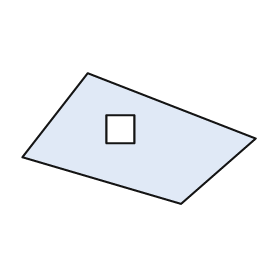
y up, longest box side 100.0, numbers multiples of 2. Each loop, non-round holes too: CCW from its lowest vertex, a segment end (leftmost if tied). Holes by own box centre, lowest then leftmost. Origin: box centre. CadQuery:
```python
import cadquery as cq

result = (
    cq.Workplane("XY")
    .moveTo(18.0, -28.0)
    .lineTo(50.0, 0.0)
    .lineTo(-22.0, 28.0)
    .lineTo(-50.0, -8.0)
    .close()
    .moveTo(-14.0, -2.0)
    .lineTo(-2.0, -2.0)
    .lineTo(-2.0, 10.0)
    .lineTo(-14.0, 10.0)
    .close()
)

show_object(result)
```